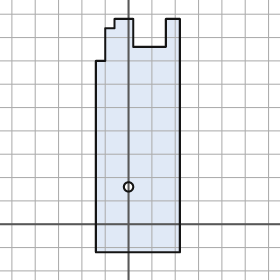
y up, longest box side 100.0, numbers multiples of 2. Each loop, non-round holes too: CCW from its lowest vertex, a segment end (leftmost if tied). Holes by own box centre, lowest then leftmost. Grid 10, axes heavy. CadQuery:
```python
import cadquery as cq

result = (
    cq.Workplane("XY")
    .moveTo(-14.0, -12.0)
    .lineTo(22.0, -12.0)
    .lineTo(22.0, 88.0)
    .lineTo(16.0, 88.0)
    .lineTo(16.0, 76.0)
    .lineTo(2.0, 76.0)
    .lineTo(2.0, 88.0)
    .lineTo(-6.0, 88.0)
    .lineTo(-6.0, 84.0)
    .lineTo(-10.0, 84.0)
    .lineTo(-10.0, 70.0)
    .lineTo(-14.0, 70.0)
    .close()
    .moveTo(0.0, 16.0)
    .circle(2.0)
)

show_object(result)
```